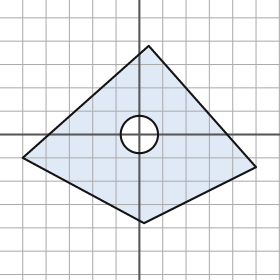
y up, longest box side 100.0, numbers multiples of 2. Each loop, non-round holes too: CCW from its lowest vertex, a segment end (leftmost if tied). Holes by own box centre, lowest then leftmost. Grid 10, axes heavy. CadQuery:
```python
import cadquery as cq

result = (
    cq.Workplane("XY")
    .moveTo(2.0, -38.0)
    .lineTo(50.0, -14.0)
    .lineTo(4.0, 38.0)
    .lineTo(-50.0, -10.0)
    .close()
    .moveTo(0.0, 0.0)
    .circle(8.0)
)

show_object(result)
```